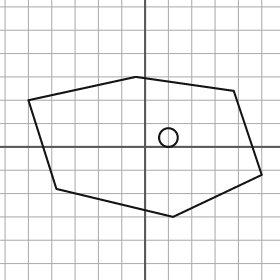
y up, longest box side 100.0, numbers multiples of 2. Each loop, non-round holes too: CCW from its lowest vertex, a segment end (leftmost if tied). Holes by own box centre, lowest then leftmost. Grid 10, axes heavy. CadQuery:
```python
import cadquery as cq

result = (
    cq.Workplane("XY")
    .moveTo(12.0, -30.0)
    .lineTo(50.0, -12.0)
    .lineTo(38.0, 24.0)
    .lineTo(-4.0, 30.0)
    .lineTo(-50.0, 20.0)
    .lineTo(-38.0, -18.0)
    .close()
    .moveTo(10.0, 4.0)
    .circle(4.0)
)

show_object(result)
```